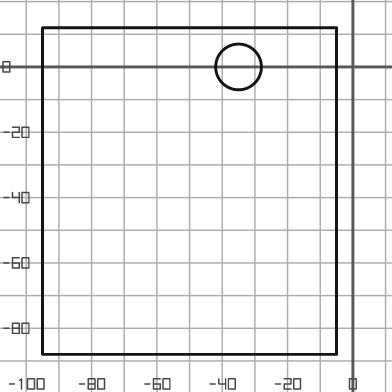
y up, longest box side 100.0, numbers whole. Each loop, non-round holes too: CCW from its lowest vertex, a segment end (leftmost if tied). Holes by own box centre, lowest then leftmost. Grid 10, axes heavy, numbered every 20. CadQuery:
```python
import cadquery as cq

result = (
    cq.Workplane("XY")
    .moveTo(-95.0, -88.0)
    .lineTo(-5.0, -88.0)
    .lineTo(-5.0, 12.0)
    .lineTo(-95.0, 12.0)
    .close()
    .moveTo(-35.0, 0.0)
    .circle(7.0)
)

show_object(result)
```